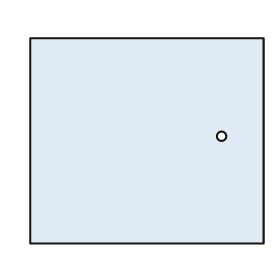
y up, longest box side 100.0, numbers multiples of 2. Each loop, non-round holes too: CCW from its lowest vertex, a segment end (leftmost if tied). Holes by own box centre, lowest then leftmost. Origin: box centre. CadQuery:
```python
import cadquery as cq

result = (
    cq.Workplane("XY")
    .moveTo(-50.0, -44.0)
    .lineTo(50.0, -44.0)
    .lineTo(50.0, 44.0)
    .lineTo(-50.0, 44.0)
    .close()
    .moveTo(32.0, 2.0)
    .circle(2.0)
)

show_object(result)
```